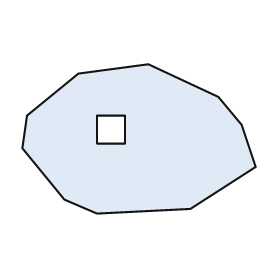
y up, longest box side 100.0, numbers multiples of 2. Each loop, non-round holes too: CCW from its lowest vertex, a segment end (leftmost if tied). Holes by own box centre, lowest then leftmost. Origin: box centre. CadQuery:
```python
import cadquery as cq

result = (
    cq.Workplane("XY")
    .moveTo(-18.0, -32.0)
    .lineTo(22.0, -30.0)
    .lineTo(50.0, -12.0)
    .lineTo(44.0, 6.0)
    .lineTo(34.0, 18.0)
    .lineTo(4.0, 32.0)
    .lineTo(-26.0, 28.0)
    .lineTo(-48.0, 10.0)
    .lineTo(-50.0, -4.0)
    .lineTo(-32.0, -26.0)
    .close()
    .moveTo(-18.0, -2.0)
    .lineTo(-6.0, -2.0)
    .lineTo(-6.0, 10.0)
    .lineTo(-18.0, 10.0)
    .close()
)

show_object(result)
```